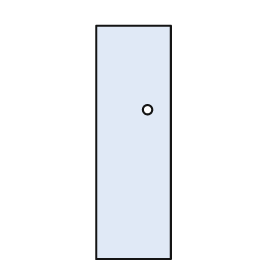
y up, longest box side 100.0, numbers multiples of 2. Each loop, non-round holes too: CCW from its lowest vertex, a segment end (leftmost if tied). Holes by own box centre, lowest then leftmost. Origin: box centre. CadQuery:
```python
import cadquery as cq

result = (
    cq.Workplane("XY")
    .moveTo(-16.0, -50.0)
    .lineTo(16.0, -50.0)
    .lineTo(16.0, 50.0)
    .lineTo(-16.0, 50.0)
    .close()
    .moveTo(6.0, 14.0)
    .circle(2.0)
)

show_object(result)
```